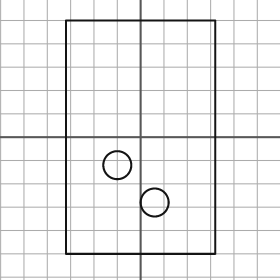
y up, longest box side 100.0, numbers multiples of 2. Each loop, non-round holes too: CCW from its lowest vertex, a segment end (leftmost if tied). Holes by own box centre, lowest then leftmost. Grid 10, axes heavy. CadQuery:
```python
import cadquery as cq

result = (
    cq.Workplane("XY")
    .moveTo(-32.0, -50.0)
    .lineTo(32.0, -50.0)
    .lineTo(32.0, 50.0)
    .lineTo(-32.0, 50.0)
    .close()
    .moveTo(6.0, -28.0)
    .circle(6.0)
    .moveTo(-10.0, -12.0)
    .circle(6.0)
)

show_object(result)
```